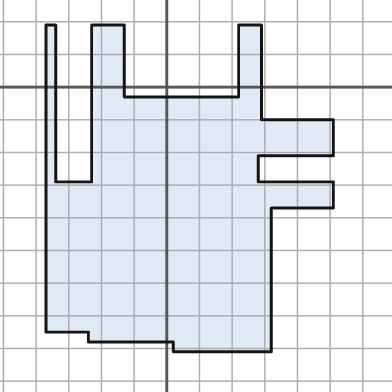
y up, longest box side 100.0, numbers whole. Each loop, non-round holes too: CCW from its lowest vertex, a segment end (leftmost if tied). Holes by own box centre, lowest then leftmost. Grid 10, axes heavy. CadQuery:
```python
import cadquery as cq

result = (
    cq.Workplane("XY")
    .moveTo(2.0, -81.0)
    .lineTo(32.0, -81.0)
    .lineTo(32.0, -37.0)
    .lineTo(51.0, -37.0)
    .lineTo(51.0, -29.0)
    .lineTo(28.0, -29.0)
    .lineTo(28.0, -21.0)
    .lineTo(51.0, -21.0)
    .lineTo(51.0, -10.0)
    .lineTo(29.0, -10.0)
    .lineTo(29.0, 19.0)
    .lineTo(22.0, 19.0)
    .lineTo(22.0, -3.0)
    .lineTo(-13.0, -3.0)
    .lineTo(-13.0, 19.0)
    .lineTo(-23.0, 19.0)
    .lineTo(-23.0, -29.0)
    .lineTo(-34.0, -29.0)
    .lineTo(-34.0, 19.0)
    .lineTo(-37.0, 19.0)
    .lineTo(-37.0, -75.0)
    .lineTo(-24.0, -75.0)
    .lineTo(-24.0, -78.0)
    .lineTo(2.0, -78.0)
    .close()
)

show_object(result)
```